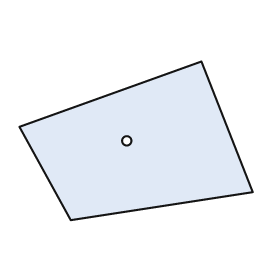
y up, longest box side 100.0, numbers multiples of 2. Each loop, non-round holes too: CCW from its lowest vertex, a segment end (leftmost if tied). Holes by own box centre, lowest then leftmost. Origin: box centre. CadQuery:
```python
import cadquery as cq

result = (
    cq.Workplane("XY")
    .moveTo(-28.0, -34.0)
    .lineTo(50.0, -22.0)
    .lineTo(28.0, 34.0)
    .lineTo(-50.0, 6.0)
    .close()
    .moveTo(-4.0, 0.0)
    .circle(2.0)
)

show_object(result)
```